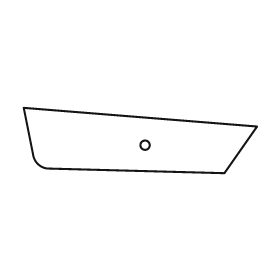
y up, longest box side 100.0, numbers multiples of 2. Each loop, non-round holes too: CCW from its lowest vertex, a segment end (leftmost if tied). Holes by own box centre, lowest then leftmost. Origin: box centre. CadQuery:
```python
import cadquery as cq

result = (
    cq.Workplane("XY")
    .moveTo(36.0, -14.0)
    .lineTo(50.0, 6.0)
    .lineTo(-50.0, 14.0)
    .lineTo(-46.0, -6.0)
    .threePointArc((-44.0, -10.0), (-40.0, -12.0))
    .close()
    .moveTo(2.0, -2.0)
    .circle(2.0)
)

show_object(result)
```